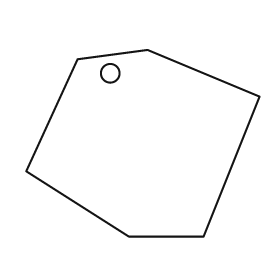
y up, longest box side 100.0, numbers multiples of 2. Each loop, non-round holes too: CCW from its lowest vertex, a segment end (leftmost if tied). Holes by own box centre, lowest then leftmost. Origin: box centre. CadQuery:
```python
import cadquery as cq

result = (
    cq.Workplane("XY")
    .moveTo(-6.0, -40.0)
    .lineTo(26.0, -40.0)
    .lineTo(50.0, 20.0)
    .lineTo(2.0, 40.0)
    .lineTo(-28.0, 36.0)
    .lineTo(-50.0, -12.0)
    .close()
    .moveTo(-14.0, 30.0)
    .circle(4.0)
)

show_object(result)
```